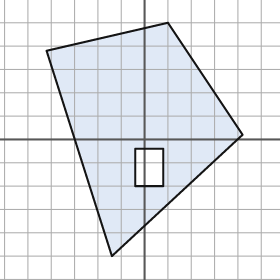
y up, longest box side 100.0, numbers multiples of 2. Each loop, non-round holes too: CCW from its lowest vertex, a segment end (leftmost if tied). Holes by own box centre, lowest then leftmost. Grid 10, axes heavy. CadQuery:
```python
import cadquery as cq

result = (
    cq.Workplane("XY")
    .moveTo(-14.0, -50.0)
    .lineTo(42.0, 2.0)
    .lineTo(10.0, 50.0)
    .lineTo(-42.0, 38.0)
    .close()
    .moveTo(-4.0, -20.0)
    .lineTo(8.0, -20.0)
    .lineTo(8.0, -4.0)
    .lineTo(-4.0, -4.0)
    .close()
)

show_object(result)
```